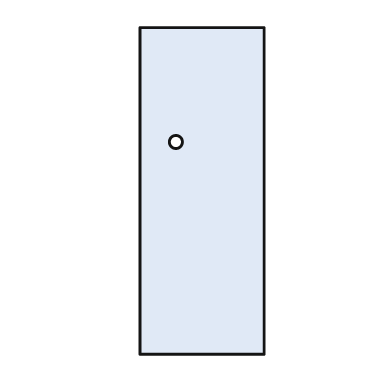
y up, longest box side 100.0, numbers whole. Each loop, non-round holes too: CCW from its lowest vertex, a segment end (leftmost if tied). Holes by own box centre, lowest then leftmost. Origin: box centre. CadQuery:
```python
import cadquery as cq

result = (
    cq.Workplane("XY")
    .moveTo(-19.0, -50.0)
    .lineTo(19.0, -50.0)
    .lineTo(19.0, 50.0)
    .lineTo(-19.0, 50.0)
    .close()
    .moveTo(-8.0, 15.0)
    .circle(2.0)
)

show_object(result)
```